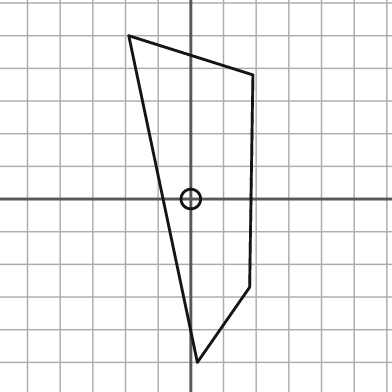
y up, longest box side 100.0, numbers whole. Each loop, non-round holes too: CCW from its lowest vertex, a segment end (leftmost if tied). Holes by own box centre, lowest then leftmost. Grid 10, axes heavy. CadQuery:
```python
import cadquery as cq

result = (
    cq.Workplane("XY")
    .moveTo(2.0, -50.0)
    .lineTo(18.0, -27.0)
    .lineTo(19.0, 38.0)
    .lineTo(-19.0, 50.0)
    .close()
    .moveTo(0.0, 0.0)
    .circle(3.0)
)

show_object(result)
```